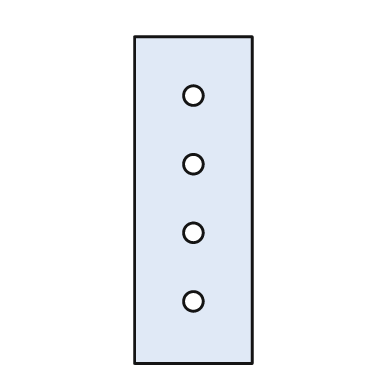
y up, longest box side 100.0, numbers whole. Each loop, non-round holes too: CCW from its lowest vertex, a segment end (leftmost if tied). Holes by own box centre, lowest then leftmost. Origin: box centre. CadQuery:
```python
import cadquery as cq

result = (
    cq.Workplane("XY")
    .moveTo(-18.0, -50.0)
    .lineTo(18.0, -50.0)
    .lineTo(18.0, 50.0)
    .lineTo(-18.0, 50.0)
    .close()
    .moveTo(0.0, -31.0)
    .circle(3.0)
    .moveTo(0.0, -10.0)
    .circle(3.0)
    .moveTo(0.0, 11.0)
    .circle(3.0)
    .moveTo(0.0, 32.0)
    .circle(3.0)
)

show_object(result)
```